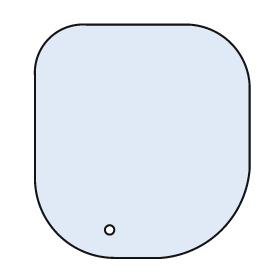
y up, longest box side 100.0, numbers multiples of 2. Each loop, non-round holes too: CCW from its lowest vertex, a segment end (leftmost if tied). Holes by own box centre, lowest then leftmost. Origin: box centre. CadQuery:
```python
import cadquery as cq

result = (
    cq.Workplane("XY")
    .moveTo(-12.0, -50.0)
    .lineTo(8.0, -50.0)
    .threePointArc((34.0, -38.0), (46.0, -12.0))
    .lineTo(46.0, 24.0)
    .threePointArc((38.0, 42.0), (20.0, 50.0))
    .lineTo(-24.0, 50.0)
    .threePointArc((-40.0, 44.0), (-46.0, 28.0))
    .lineTo(-46.0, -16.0)
    .threePointArc((-36.0, -40.0), (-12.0, -50.0))
    .close()
    .moveTo(-14.0, -38.0)
    .circle(2.0)
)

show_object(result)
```